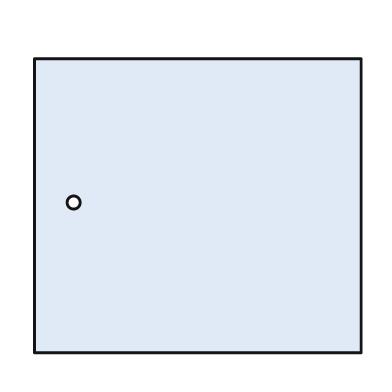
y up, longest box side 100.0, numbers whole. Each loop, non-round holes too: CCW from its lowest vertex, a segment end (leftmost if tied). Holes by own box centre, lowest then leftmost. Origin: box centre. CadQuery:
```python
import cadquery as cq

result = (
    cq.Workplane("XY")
    .moveTo(-50.0, -45.0)
    .lineTo(50.0, -45.0)
    .lineTo(50.0, 45.0)
    .lineTo(-50.0, 45.0)
    .close()
    .moveTo(-38.0, 1.0)
    .circle(2.0)
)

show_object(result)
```